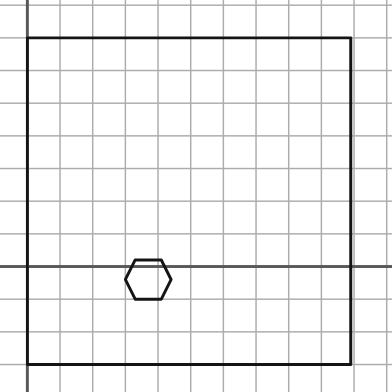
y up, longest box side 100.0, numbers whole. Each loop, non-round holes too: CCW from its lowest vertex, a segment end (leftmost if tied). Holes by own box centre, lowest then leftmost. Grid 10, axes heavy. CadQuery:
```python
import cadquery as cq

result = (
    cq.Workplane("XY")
    .moveTo(0.0, -30.0)
    .lineTo(99.0, -30.0)
    .lineTo(99.0, 70.0)
    .lineTo(0.0, 70.0)
    .close()
    .moveTo(33.0, -10.0)
    .lineTo(41.0, -10.0)
    .lineTo(44.0, -4.0)
    .lineTo(41.0, 2.0)
    .lineTo(33.0, 2.0)
    .lineTo(30.0, -4.0)
    .close()
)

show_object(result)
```